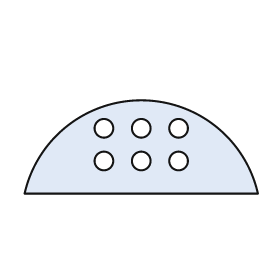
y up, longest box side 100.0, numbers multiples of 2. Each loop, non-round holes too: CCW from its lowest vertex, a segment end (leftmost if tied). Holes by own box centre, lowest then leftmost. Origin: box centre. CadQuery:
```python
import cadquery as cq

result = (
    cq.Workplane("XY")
    .moveTo(-50.0, -20.0)
    .lineTo(50.0, -20.0)
    .threePointArc((0.0, 20.0), (-50.0, -20.0))
    .close()
    .moveTo(-16.0, -6.0)
    .circle(4.0)
    .moveTo(0.0, -6.0)
    .circle(4.0)
    .moveTo(16.0, -6.0)
    .circle(4.0)
    .moveTo(-16.0, 8.0)
    .circle(4.0)
    .moveTo(0.0, 8.0)
    .circle(4.0)
    .moveTo(16.0, 8.0)
    .circle(4.0)
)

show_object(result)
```